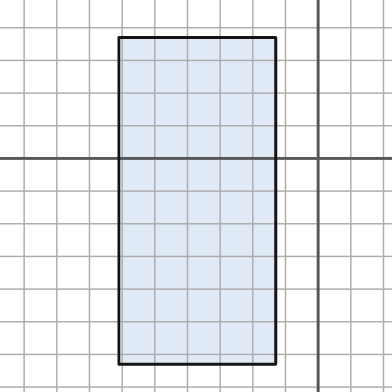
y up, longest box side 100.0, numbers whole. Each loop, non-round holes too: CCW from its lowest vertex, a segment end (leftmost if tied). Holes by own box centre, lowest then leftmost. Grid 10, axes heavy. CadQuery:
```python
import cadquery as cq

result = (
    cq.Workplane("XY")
    .moveTo(-61.0, -63.0)
    .lineTo(-13.0, -63.0)
    .lineTo(-13.0, 37.0)
    .lineTo(-61.0, 37.0)
    .close()
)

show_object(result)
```